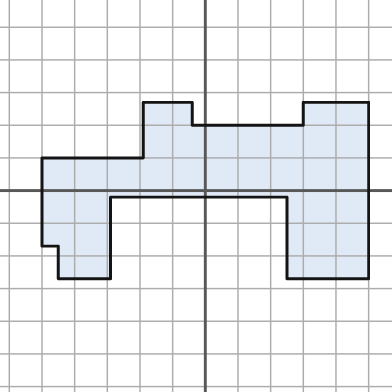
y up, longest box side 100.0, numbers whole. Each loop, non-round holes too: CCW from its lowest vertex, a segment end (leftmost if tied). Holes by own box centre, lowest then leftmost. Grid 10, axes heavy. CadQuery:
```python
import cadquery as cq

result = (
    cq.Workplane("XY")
    .moveTo(-45.0, -27.0)
    .lineTo(-29.0, -27.0)
    .lineTo(-29.0, -2.0)
    .lineTo(25.0, -2.0)
    .lineTo(25.0, -27.0)
    .lineTo(50.0, -27.0)
    .lineTo(50.0, 27.0)
    .lineTo(30.0, 27.0)
    .lineTo(30.0, 20.0)
    .lineTo(-4.0, 20.0)
    .lineTo(-4.0, 27.0)
    .lineTo(-19.0, 27.0)
    .lineTo(-19.0, 10.0)
    .lineTo(-50.0, 10.0)
    .lineTo(-50.0, -17.0)
    .lineTo(-45.0, -17.0)
    .close()
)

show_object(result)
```